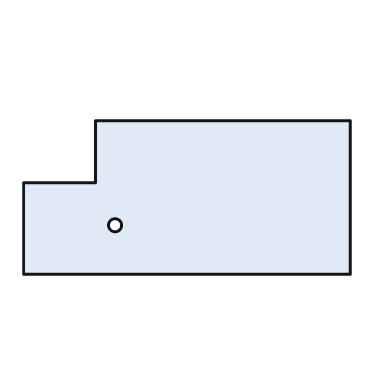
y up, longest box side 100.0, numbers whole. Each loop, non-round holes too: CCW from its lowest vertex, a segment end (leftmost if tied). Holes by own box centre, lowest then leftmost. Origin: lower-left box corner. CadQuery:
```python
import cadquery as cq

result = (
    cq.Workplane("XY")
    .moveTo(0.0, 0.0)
    .lineTo(100.0, 0.0)
    .lineTo(100.0, 47.0)
    .lineTo(22.0, 47.0)
    .lineTo(22.0, 28.0)
    .lineTo(0.0, 28.0)
    .close()
    .moveTo(28.0, 15.0)
    .circle(2.0)
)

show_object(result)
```